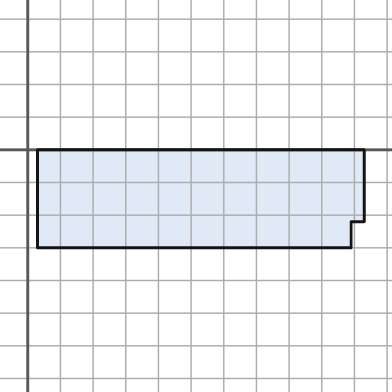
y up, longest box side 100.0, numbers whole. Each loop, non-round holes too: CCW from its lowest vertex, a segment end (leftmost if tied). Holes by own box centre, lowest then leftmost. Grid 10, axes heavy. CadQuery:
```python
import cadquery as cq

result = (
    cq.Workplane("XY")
    .moveTo(3.0, -30.0)
    .lineTo(99.0, -30.0)
    .lineTo(99.0, -22.0)
    .lineTo(103.0, -22.0)
    .lineTo(103.0, 0.0)
    .lineTo(3.0, 0.0)
    .close()
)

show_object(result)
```